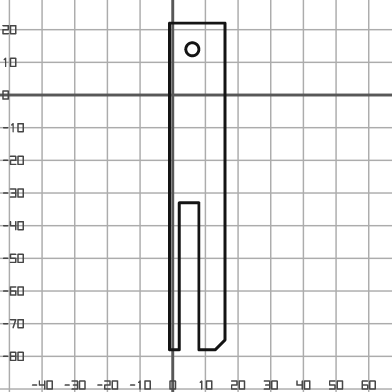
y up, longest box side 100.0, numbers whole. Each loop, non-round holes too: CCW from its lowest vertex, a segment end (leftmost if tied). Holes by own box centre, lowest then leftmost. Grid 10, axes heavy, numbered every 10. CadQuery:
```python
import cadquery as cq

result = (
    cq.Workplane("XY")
    .moveTo(-1.0, -78.0)
    .lineTo(2.0, -78.0)
    .lineTo(2.0, -33.0)
    .lineTo(8.0, -33.0)
    .lineTo(8.0, -78.0)
    .lineTo(13.0, -78.0)
    .lineTo(16.0, -75.0)
    .lineTo(16.0, 22.0)
    .lineTo(-1.0, 22.0)
    .close()
    .moveTo(6.0, 14.0)
    .circle(2.0)
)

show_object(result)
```